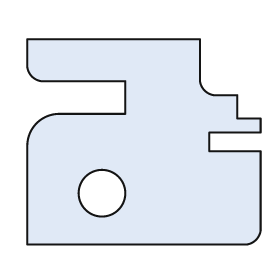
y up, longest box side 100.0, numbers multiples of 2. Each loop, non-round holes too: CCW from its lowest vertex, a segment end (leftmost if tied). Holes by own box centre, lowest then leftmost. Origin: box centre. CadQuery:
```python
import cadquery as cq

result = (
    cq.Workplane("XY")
    .moveTo(-50.0, -44.0)
    .lineTo(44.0, -44.0)
    .threePointArc((48.0, -42.0), (50.0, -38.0))
    .lineTo(50.0, -4.0)
    .lineTo(28.0, -4.0)
    .lineTo(28.0, 4.0)
    .lineTo(50.0, 4.0)
    .lineTo(50.0, 10.0)
    .lineTo(40.0, 10.0)
    .lineTo(40.0, 20.0)
    .lineTo(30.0, 20.0)
    .threePointArc((26.0, 22.0), (24.0, 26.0))
    .lineTo(24.0, 44.0)
    .lineTo(-50.0, 44.0)
    .lineTo(-50.0, 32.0)
    .threePointArc((-48.0, 28.0), (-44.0, 26.0))
    .lineTo(-8.0, 26.0)
    .lineTo(-8.0, 12.0)
    .lineTo(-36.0, 12.0)
    .threePointArc((-46.0, 8.0), (-50.0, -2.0))
    .close()
    .moveTo(-18.0, -22.0)
    .circle(10.0)
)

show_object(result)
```